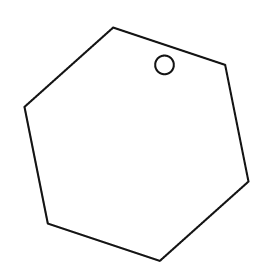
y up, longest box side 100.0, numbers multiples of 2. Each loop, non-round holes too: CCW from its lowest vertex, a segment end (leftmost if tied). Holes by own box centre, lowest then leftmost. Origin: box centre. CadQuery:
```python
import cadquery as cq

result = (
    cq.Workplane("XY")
    .moveTo(10.0, -50.0)
    .lineTo(48.0, -16.0)
    .lineTo(38.0, 34.0)
    .lineTo(-10.0, 50.0)
    .lineTo(-48.0, 16.0)
    .lineTo(-38.0, -34.0)
    .close()
    .moveTo(12.0, 34.0)
    .circle(4.0)
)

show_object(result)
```